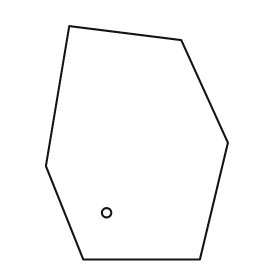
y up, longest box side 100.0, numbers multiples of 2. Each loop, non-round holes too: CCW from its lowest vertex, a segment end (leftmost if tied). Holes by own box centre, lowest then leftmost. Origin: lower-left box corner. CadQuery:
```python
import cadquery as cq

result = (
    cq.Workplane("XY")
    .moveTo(16.0, 0.0)
    .lineTo(66.0, 0.0)
    .lineTo(78.0, 50.0)
    .lineTo(58.0, 94.0)
    .lineTo(10.0, 100.0)
    .lineTo(0.0, 40.0)
    .close()
    .moveTo(26.0, 20.0)
    .circle(2.0)
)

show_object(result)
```